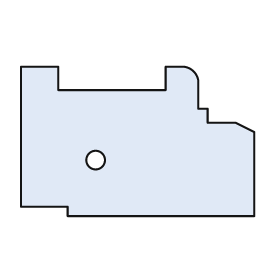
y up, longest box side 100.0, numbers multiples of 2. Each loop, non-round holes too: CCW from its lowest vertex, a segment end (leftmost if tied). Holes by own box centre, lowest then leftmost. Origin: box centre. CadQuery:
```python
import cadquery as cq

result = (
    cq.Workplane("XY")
    .moveTo(-30.0, -32.0)
    .lineTo(50.0, -32.0)
    .lineTo(50.0, 4.0)
    .lineTo(42.0, 8.0)
    .lineTo(30.0, 8.0)
    .lineTo(30.0, 14.0)
    .lineTo(26.0, 14.0)
    .lineTo(26.0, 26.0)
    .threePointArc((24.0, 30.0), (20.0, 32.0))
    .lineTo(12.0, 32.0)
    .lineTo(12.0, 22.0)
    .lineTo(-34.0, 22.0)
    .lineTo(-34.0, 32.0)
    .lineTo(-50.0, 32.0)
    .lineTo(-50.0, -28.0)
    .lineTo(-30.0, -28.0)
    .close()
    .moveTo(-18.0, -8.0)
    .circle(4.0)
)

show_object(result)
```